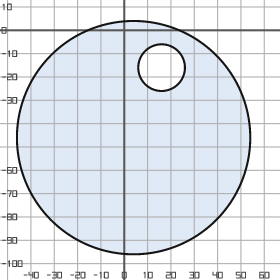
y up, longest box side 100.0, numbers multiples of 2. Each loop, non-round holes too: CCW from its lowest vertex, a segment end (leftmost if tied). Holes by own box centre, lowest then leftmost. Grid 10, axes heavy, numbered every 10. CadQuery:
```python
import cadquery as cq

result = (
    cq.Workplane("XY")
    .moveTo(4.0, -46.0)
    .circle(50.0)
    .moveTo(16.0, -16.0)
    .circle(10.0)
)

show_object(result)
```